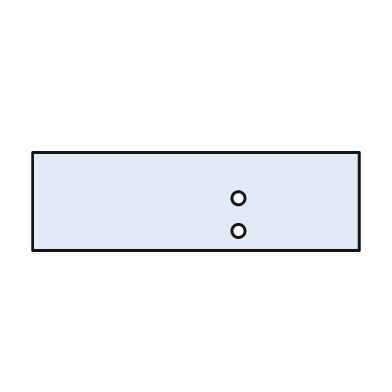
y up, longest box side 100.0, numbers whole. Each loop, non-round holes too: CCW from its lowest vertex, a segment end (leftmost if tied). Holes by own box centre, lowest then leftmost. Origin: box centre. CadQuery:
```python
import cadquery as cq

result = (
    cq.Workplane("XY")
    .moveTo(-50.0, -15.0)
    .lineTo(50.0, -15.0)
    .lineTo(50.0, 15.0)
    .lineTo(-50.0, 15.0)
    .close()
    .moveTo(13.0, -9.0)
    .circle(2.0)
    .moveTo(13.0, 1.0)
    .circle(2.0)
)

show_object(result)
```